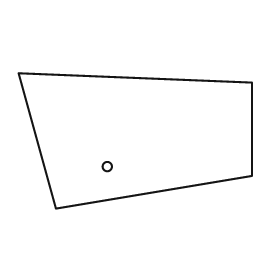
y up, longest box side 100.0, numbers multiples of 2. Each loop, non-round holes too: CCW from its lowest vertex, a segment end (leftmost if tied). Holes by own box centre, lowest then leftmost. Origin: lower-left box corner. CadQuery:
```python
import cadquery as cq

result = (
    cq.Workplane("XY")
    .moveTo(16.0, 0.0)
    .lineTo(100.0, 14.0)
    .lineTo(100.0, 54.0)
    .lineTo(0.0, 58.0)
    .close()
    .moveTo(38.0, 18.0)
    .circle(2.0)
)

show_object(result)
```